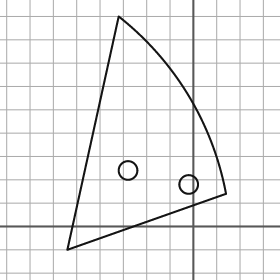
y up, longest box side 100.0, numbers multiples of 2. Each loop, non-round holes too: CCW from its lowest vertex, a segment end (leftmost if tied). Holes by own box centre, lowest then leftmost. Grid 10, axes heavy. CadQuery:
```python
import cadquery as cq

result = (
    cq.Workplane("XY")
    .moveTo(-54.0, -10.0)
    .lineTo(14.0, 14.0)
    .threePointArc((-2.0, 56.0), (-32.0, 90.0))
    .close()
    .moveTo(-2.0, 18.0)
    .circle(4.0)
    .moveTo(-28.0, 24.0)
    .circle(4.0)
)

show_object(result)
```